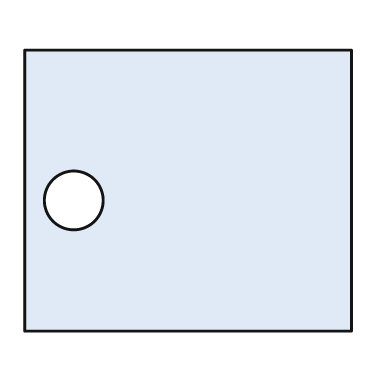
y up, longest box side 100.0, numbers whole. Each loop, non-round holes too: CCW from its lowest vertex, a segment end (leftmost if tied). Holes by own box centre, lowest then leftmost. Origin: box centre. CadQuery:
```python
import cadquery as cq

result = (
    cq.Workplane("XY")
    .moveTo(-50.0, -43.0)
    .lineTo(50.0, -43.0)
    .lineTo(50.0, 43.0)
    .lineTo(-50.0, 43.0)
    .close()
    .moveTo(-35.0, -3.0)
    .circle(9.0)
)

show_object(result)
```